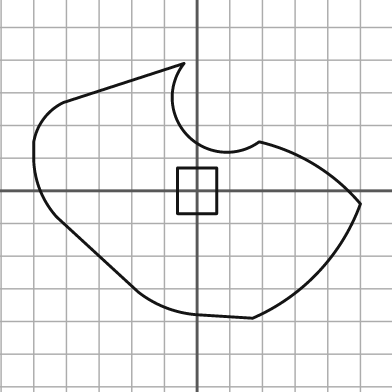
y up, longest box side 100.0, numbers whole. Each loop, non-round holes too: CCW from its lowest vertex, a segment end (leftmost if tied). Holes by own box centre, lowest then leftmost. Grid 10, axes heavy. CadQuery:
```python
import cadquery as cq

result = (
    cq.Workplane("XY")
    .moveTo(17.0, -39.0)
    .threePointArc((37.0, -25.0), (50.0, -4.0))
    .threePointArc((36.0, 8.0), (19.0, 15.0))
    .threePointArc((-3.0, 17.0), (-4.0, 39.0))
    .lineTo(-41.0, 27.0)
    .threePointArc((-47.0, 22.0), (-50.0, 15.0))
    .lineTo(-50.0, 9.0)
    .threePointArc((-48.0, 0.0), (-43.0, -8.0))
    .lineTo(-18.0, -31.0)
    .threePointArc((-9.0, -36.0), (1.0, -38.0))
    .close()
    .moveTo(-6.0, -7.0)
    .lineTo(6.0, -7.0)
    .lineTo(6.0, 7.0)
    .lineTo(-6.0, 7.0)
    .close()
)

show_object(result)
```